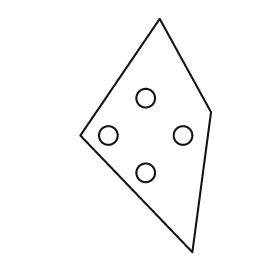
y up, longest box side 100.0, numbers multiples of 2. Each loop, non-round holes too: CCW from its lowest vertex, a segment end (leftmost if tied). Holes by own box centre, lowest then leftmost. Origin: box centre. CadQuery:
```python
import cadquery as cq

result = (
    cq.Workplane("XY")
    .moveTo(20.0, -50.0)
    .lineTo(28.0, 10.0)
    .lineTo(6.0, 50.0)
    .lineTo(-28.0, 0.0)
    .close()
    .moveTo(0.0, -16.0)
    .circle(4.0)
    .moveTo(-16.0, 0.0)
    .circle(4.0)
    .moveTo(16.0, 0.0)
    .circle(4.0)
    .moveTo(0.0, 16.0)
    .circle(4.0)
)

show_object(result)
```